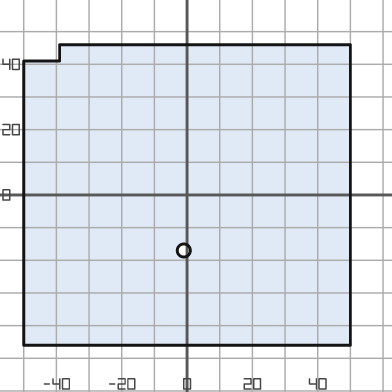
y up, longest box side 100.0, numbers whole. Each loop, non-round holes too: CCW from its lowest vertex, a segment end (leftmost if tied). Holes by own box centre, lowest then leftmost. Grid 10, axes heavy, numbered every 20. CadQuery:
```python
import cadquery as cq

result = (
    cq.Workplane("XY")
    .moveTo(-50.0, -46.0)
    .lineTo(50.0, -46.0)
    .lineTo(50.0, 46.0)
    .lineTo(-39.0, 46.0)
    .lineTo(-39.0, 41.0)
    .lineTo(-50.0, 41.0)
    .close()
    .moveTo(-1.0, -17.0)
    .circle(2.0)
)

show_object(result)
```